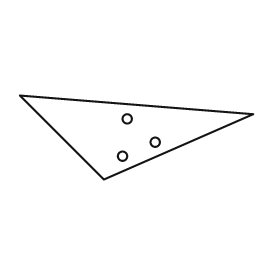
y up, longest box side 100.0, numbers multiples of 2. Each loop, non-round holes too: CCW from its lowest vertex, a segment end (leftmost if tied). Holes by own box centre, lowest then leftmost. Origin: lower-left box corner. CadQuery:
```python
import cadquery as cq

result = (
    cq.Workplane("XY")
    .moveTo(36.0, 0.0)
    .lineTo(100.0, 28.0)
    .lineTo(0.0, 36.0)
    .close()
    .moveTo(44.0, 10.0)
    .circle(2.0)
    .moveTo(58.0, 16.0)
    .circle(2.0)
    .moveTo(46.0, 26.0)
    .circle(2.0)
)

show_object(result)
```